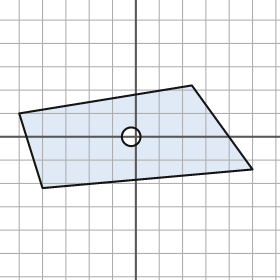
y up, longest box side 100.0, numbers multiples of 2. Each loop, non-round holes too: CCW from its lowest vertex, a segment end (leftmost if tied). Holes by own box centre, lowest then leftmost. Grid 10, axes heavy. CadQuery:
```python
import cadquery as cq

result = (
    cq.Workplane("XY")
    .moveTo(-40.0, -22.0)
    .lineTo(50.0, -14.0)
    .lineTo(24.0, 22.0)
    .lineTo(-50.0, 10.0)
    .close()
    .moveTo(-2.0, 0.0)
    .circle(4.0)
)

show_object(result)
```